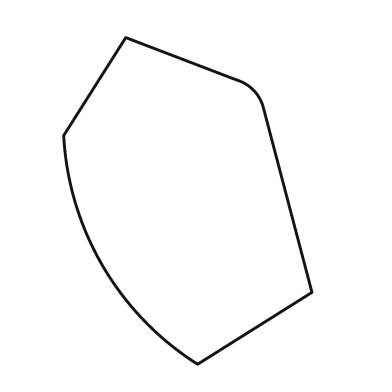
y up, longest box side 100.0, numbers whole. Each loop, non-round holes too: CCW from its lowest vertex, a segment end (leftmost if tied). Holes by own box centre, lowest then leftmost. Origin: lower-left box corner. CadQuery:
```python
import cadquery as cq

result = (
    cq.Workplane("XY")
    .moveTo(41.0, 0.0)
    .lineTo(76.0, 22.0)
    .lineTo(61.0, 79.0)
    .threePointArc((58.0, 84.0), (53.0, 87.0))
    .lineTo(19.0, 100.0)
    .lineTo(0.0, 70.0)
    .threePointArc((12.0, 30.0), (41.0, 0.0))
    .close()
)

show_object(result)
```